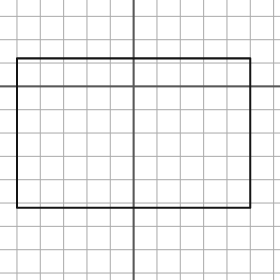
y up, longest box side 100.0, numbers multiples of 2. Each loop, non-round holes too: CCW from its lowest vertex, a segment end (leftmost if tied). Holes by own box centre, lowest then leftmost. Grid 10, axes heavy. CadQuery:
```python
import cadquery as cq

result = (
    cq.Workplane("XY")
    .moveTo(-50.0, -52.0)
    .lineTo(50.0, -52.0)
    .lineTo(50.0, 12.0)
    .lineTo(-50.0, 12.0)
    .close()
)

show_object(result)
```